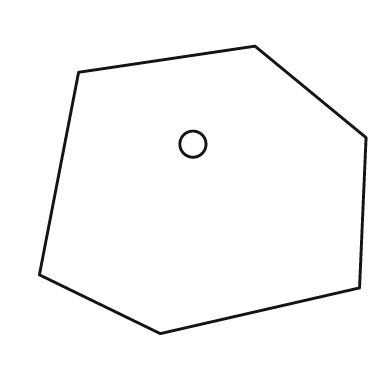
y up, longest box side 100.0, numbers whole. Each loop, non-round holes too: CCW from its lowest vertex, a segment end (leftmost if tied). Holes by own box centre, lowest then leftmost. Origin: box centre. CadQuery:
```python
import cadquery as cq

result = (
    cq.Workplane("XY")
    .moveTo(-13.0, -44.0)
    .lineTo(48.0, -30.0)
    .lineTo(50.0, 16.0)
    .lineTo(16.0, 44.0)
    .lineTo(-38.0, 36.0)
    .lineTo(-50.0, -26.0)
    .close()
    .moveTo(-3.0, 14.0)
    .circle(4.0)
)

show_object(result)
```